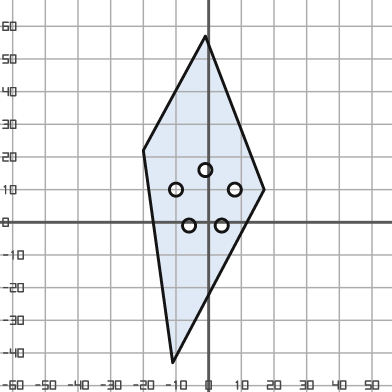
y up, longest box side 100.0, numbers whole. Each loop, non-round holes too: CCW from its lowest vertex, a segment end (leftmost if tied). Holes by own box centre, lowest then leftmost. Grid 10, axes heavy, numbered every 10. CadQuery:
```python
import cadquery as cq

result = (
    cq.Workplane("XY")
    .moveTo(-11.0, -43.0)
    .lineTo(17.0, 10.0)
    .lineTo(-1.0, 57.0)
    .lineTo(-20.0, 22.0)
    .close()
    .moveTo(-6.0, -1.0)
    .circle(2.0)
    .moveTo(4.0, -1.0)
    .circle(2.0)
    .moveTo(-10.0, 10.0)
    .circle(2.0)
    .moveTo(8.0, 10.0)
    .circle(2.0)
    .moveTo(-1.0, 16.0)
    .circle(2.0)
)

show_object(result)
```